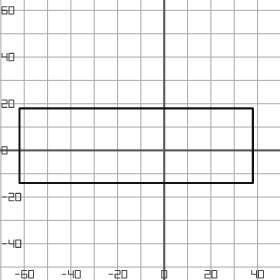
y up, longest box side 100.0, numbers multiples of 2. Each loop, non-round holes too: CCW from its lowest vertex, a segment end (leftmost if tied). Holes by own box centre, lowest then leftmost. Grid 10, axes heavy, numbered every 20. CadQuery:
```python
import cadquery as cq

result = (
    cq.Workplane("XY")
    .moveTo(-62.0, -14.0)
    .lineTo(38.0, -14.0)
    .lineTo(38.0, 18.0)
    .lineTo(-62.0, 18.0)
    .close()
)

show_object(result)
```